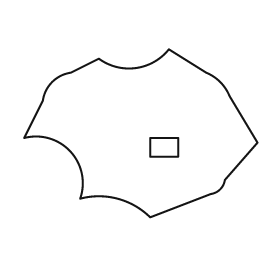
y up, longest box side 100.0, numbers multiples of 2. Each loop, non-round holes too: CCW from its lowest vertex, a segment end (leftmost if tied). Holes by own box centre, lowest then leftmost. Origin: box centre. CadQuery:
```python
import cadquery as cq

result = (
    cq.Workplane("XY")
    .moveTo(4.0, -36.0)
    .lineTo(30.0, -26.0)
    .threePointArc((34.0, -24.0), (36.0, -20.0))
    .lineTo(50.0, -4.0)
    .lineTo(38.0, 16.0)
    .threePointArc((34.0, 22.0), (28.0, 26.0))
    .lineTo(12.0, 36.0)
    .threePointArc((-2.0, 28.0), (-18.0, 32.0))
    .lineTo(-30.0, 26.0)
    .threePointArc((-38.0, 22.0), (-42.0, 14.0))
    .lineTo(-50.0, -2.0)
    .threePointArc((-30.0, -8.0), (-26.0, -28.0))
    .threePointArc((-10.0, -28.0), (4.0, -36.0))
    .close()
    .moveTo(4.0, -10.0)
    .lineTo(16.0, -10.0)
    .lineTo(16.0, -2.0)
    .lineTo(4.0, -2.0)
    .close()
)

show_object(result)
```